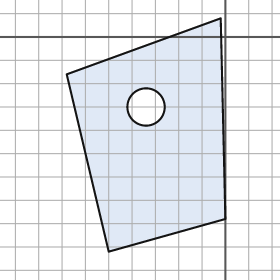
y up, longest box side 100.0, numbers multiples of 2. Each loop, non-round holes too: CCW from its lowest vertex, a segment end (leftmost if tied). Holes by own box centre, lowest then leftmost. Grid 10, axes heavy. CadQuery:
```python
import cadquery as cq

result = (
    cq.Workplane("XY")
    .moveTo(-50.0, -92.0)
    .lineTo(0.0, -78.0)
    .lineTo(-2.0, 8.0)
    .lineTo(-68.0, -16.0)
    .close()
    .moveTo(-34.0, -30.0)
    .circle(8.0)
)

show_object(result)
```